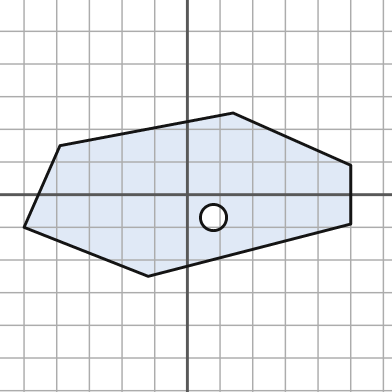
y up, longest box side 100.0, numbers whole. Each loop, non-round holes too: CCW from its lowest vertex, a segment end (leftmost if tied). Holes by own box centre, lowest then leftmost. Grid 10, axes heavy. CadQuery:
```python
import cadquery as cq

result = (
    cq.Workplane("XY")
    .moveTo(-12.0, -25.0)
    .lineTo(50.0, -9.0)
    .lineTo(50.0, 9.0)
    .lineTo(14.0, 25.0)
    .lineTo(-39.0, 15.0)
    .lineTo(-50.0, -10.0)
    .close()
    .moveTo(8.0, -7.0)
    .circle(4.0)
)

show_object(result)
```